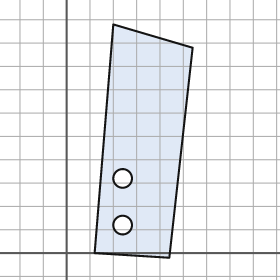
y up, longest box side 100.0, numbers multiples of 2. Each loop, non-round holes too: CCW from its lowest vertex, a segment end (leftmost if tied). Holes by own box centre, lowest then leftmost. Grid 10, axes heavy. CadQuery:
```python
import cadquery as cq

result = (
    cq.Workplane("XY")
    .moveTo(44.0, -2.0)
    .lineTo(54.0, 88.0)
    .lineTo(20.0, 98.0)
    .lineTo(12.0, 0.0)
    .close()
    .moveTo(24.0, 12.0)
    .circle(4.0)
    .moveTo(24.0, 32.0)
    .circle(4.0)
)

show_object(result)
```